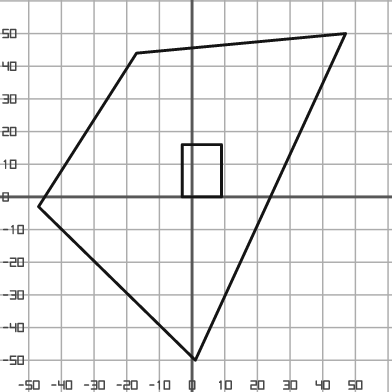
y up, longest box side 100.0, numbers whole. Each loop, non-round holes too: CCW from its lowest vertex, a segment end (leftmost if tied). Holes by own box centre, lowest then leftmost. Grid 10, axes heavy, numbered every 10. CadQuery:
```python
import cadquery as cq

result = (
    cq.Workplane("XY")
    .moveTo(1.0, -50.0)
    .lineTo(47.0, 50.0)
    .lineTo(-17.0, 44.0)
    .lineTo(-47.0, -3.0)
    .close()
    .moveTo(-3.0, 0.0)
    .lineTo(9.0, 0.0)
    .lineTo(9.0, 16.0)
    .lineTo(-3.0, 16.0)
    .close()
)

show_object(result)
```